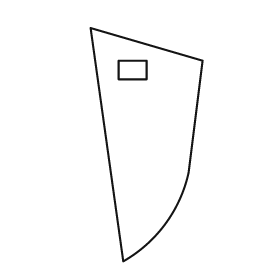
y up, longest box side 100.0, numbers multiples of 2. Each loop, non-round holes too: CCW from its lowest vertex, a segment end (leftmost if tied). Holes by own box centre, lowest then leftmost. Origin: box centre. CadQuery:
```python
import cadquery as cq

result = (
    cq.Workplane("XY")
    .moveTo(-10.0, -50.0)
    .threePointArc((8.0, -34.0), (18.0, -12.0))
    .lineTo(24.0, 36.0)
    .lineTo(-24.0, 50.0)
    .close()
    .moveTo(-12.0, 28.0)
    .lineTo(0.0, 28.0)
    .lineTo(0.0, 36.0)
    .lineTo(-12.0, 36.0)
    .close()
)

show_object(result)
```